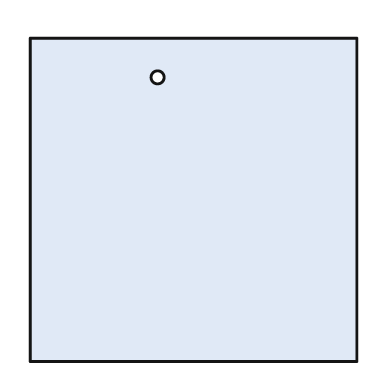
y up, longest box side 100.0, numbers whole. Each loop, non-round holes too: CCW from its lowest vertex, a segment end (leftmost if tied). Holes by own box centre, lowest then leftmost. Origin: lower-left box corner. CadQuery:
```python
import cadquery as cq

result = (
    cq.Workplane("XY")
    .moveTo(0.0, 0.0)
    .lineTo(100.0, 0.0)
    .lineTo(100.0, 99.0)
    .lineTo(0.0, 99.0)
    .close()
    .moveTo(39.0, 87.0)
    .circle(2.0)
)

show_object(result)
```